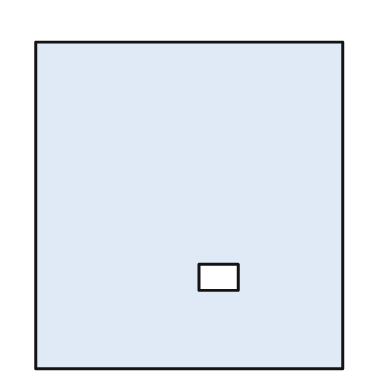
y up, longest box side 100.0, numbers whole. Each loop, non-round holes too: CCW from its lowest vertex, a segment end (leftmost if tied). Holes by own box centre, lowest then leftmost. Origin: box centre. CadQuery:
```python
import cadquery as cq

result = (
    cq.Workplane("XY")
    .moveTo(-47.0, -50.0)
    .lineTo(47.0, -50.0)
    .lineTo(47.0, 50.0)
    .lineTo(-47.0, 50.0)
    .close()
    .moveTo(3.0, -26.0)
    .lineTo(15.0, -26.0)
    .lineTo(15.0, -18.0)
    .lineTo(3.0, -18.0)
    .close()
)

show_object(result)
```